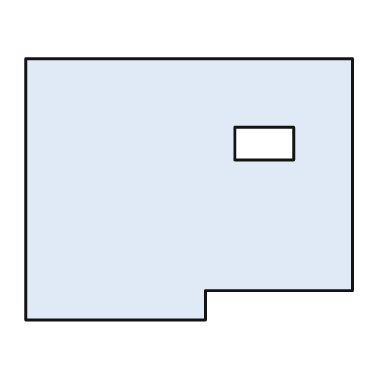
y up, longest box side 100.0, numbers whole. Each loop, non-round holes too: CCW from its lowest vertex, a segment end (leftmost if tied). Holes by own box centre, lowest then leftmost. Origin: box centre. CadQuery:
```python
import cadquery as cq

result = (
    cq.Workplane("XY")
    .moveTo(-50.0, -40.0)
    .lineTo(5.0, -40.0)
    .lineTo(5.0, -31.0)
    .lineTo(50.0, -31.0)
    .lineTo(50.0, 40.0)
    .lineTo(-50.0, 40.0)
    .close()
    .moveTo(14.0, 9.0)
    .lineTo(32.0, 9.0)
    .lineTo(32.0, 19.0)
    .lineTo(14.0, 19.0)
    .close()
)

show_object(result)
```